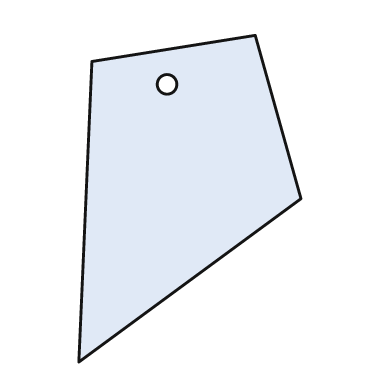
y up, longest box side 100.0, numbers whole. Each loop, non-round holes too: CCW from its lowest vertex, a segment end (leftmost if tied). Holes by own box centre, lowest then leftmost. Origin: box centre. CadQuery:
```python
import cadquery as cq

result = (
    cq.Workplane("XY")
    .moveTo(-34.0, -50.0)
    .lineTo(34.0, 0.0)
    .lineTo(20.0, 50.0)
    .lineTo(-30.0, 42.0)
    .close()
    .moveTo(-7.0, 35.0)
    .circle(3.0)
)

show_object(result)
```